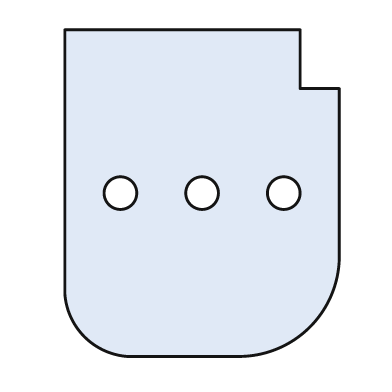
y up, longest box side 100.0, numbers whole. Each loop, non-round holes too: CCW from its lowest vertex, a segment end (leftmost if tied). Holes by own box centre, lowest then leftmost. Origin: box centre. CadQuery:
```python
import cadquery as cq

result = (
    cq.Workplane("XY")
    .moveTo(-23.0, -50.0)
    .lineTo(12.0, -50.0)
    .threePointArc((33.0, -41.0), (42.0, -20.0))
    .lineTo(42.0, 32.0)
    .lineTo(30.0, 32.0)
    .lineTo(30.0, 50.0)
    .lineTo(-42.0, 50.0)
    .lineTo(-42.0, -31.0)
    .threePointArc((-36.0, -44.0), (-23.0, -50.0))
    .close()
    .moveTo(-25.0, 0.0)
    .circle(5.0)
    .moveTo(0.0, 0.0)
    .circle(5.0)
    .moveTo(25.0, 0.0)
    .circle(5.0)
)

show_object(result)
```